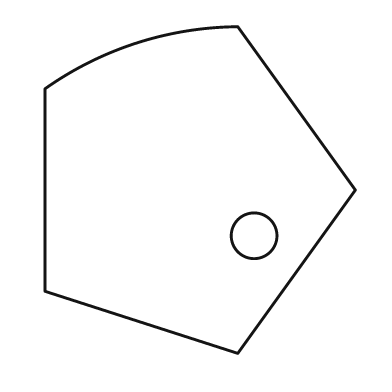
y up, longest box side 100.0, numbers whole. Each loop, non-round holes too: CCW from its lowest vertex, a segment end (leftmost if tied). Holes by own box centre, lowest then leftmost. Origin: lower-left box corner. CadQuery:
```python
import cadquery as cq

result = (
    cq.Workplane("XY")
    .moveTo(59.0, 0.0)
    .lineTo(95.0, 50.0)
    .lineTo(59.0, 100.0)
    .threePointArc((28.0, 95.0), (0.0, 81.0))
    .lineTo(0.0, 19.0)
    .close()
    .moveTo(64.0, 36.0)
    .circle(7.0)
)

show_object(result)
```